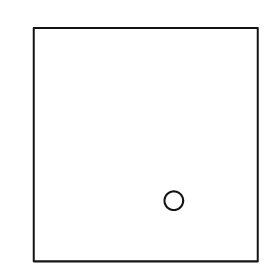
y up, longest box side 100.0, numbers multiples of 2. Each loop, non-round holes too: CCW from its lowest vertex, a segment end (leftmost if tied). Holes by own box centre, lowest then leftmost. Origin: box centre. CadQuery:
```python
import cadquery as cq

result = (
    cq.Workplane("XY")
    .moveTo(-48.0, -50.0)
    .lineTo(48.0, -50.0)
    .lineTo(48.0, 50.0)
    .lineTo(-48.0, 50.0)
    .close()
    .moveTo(12.0, -24.0)
    .circle(4.0)
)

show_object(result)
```